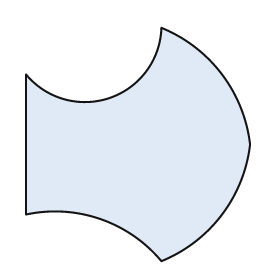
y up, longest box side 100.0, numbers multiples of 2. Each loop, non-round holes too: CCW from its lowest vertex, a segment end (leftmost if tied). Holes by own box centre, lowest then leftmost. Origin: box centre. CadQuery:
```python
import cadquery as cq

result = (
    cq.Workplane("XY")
    .moveTo(10.0, -50.0)
    .threePointArc((36.0, -30.0), (48.0, 0.0))
    .threePointArc((36.0, 30.0), (10.0, 50.0))
    .threePointArc((-12.0, 20.0), (-48.0, 30.0))
    .lineTo(-48.0, -30.0)
    .threePointArc((-16.0, -32.0), (10.0, -50.0))
    .close()
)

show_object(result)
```